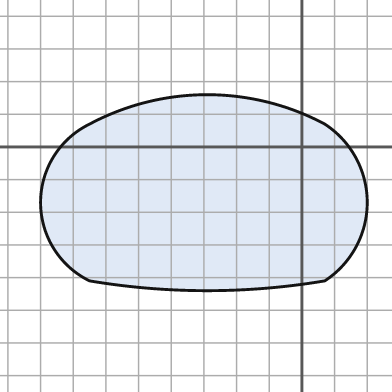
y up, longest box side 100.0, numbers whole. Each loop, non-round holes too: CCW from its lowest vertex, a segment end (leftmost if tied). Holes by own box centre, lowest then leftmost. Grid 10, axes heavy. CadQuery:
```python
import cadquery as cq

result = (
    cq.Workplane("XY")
    .moveTo(-65.0, -41.0)
    .threePointArc((-29.0, -44.0), (7.0, -41.0))
    .threePointArc((20.0, -17.0), (7.0, 7.0))
    .threePointArc((-29.0, 16.0), (-65.0, 7.0))
    .threePointArc((-80.0, -17.0), (-65.0, -41.0))
    .close()
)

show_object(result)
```